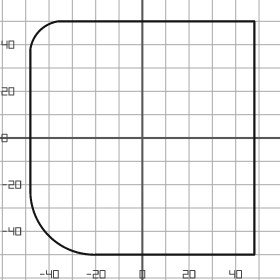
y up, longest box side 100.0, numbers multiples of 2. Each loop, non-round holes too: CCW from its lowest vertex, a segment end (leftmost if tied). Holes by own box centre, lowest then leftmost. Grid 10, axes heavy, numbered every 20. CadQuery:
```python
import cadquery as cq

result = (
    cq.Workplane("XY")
    .moveTo(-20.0, -50.0)
    .lineTo(48.0, -50.0)
    .lineTo(48.0, 50.0)
    .lineTo(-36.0, 50.0)
    .threePointArc((-44.0, 46.0), (-48.0, 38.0))
    .lineTo(-48.0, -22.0)
    .threePointArc((-40.0, -42.0), (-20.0, -50.0))
    .close()
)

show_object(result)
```